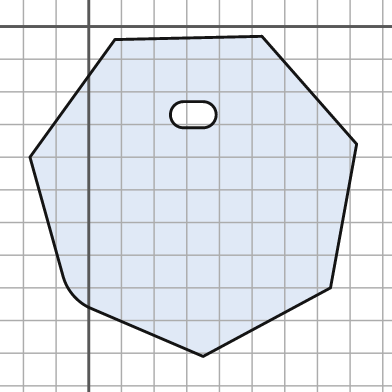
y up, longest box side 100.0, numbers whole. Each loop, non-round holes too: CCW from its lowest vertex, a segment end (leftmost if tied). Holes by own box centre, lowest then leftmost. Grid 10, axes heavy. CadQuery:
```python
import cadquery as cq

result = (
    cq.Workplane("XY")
    .moveTo(35.0, -101.0)
    .lineTo(74.0, -80.0)
    .lineTo(82.0, -36.0)
    .lineTo(53.0, -3.0)
    .lineTo(8.0, -4.0)
    .lineTo(-18.0, -40.0)
    .lineTo(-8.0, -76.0)
    .threePointArc((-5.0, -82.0), (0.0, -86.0))
    .close()
    .moveTo(29.0, -31.0)
    .lineTo(35.0, -31.0)
    .threePointArc((39.0, -27.0), (35.0, -23.0))
    .lineTo(29.0, -23.0)
    .threePointArc((25.0, -27.0), (29.0, -31.0))
    .close()
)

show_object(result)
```